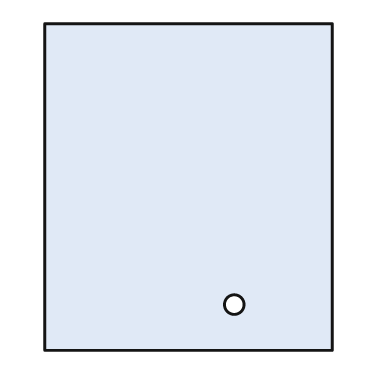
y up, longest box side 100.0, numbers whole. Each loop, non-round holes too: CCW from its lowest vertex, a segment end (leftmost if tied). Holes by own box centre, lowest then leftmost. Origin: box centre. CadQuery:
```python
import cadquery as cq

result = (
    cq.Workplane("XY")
    .moveTo(-44.0, -50.0)
    .lineTo(44.0, -50.0)
    .lineTo(44.0, 50.0)
    .lineTo(-44.0, 50.0)
    .close()
    .moveTo(14.0, -36.0)
    .circle(3.0)
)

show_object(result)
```